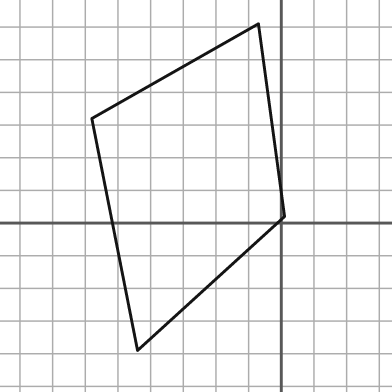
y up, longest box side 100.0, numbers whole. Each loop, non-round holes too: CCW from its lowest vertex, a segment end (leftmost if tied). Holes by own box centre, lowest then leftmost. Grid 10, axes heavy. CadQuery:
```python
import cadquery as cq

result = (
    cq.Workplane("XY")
    .moveTo(-44.0, -39.0)
    .lineTo(1.0, 2.0)
    .lineTo(-7.0, 61.0)
    .lineTo(-58.0, 32.0)
    .close()
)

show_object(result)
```